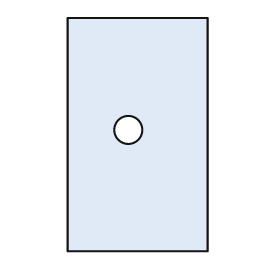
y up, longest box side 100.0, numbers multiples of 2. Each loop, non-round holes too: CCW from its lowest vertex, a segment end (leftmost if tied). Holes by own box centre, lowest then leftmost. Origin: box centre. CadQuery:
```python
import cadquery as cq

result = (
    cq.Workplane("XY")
    .moveTo(-30.0, -50.0)
    .lineTo(30.0, -50.0)
    .lineTo(30.0, 50.0)
    .lineTo(-30.0, 50.0)
    .close()
    .moveTo(-4.0, 2.0)
    .circle(6.0)
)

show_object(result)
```